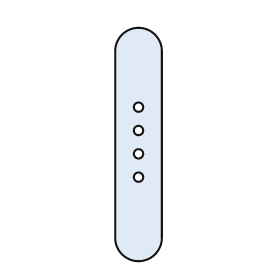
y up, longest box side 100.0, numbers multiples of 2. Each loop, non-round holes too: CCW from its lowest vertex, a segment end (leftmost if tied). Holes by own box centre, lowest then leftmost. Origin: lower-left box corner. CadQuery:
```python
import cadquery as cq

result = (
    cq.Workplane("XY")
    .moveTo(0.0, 10.0)
    .threePointArc((10.0, 0.0), (20.0, 10.0))
    .lineTo(20.0, 90.0)
    .threePointArc((10.0, 100.0), (0.0, 90.0))
    .close()
    .moveTo(10.0, 36.0)
    .circle(2.0)
    .moveTo(10.0, 46.0)
    .circle(2.0)
    .moveTo(10.0, 56.0)
    .circle(2.0)
    .moveTo(10.0, 66.0)
    .circle(2.0)
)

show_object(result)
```